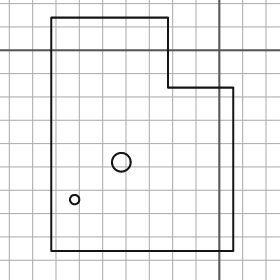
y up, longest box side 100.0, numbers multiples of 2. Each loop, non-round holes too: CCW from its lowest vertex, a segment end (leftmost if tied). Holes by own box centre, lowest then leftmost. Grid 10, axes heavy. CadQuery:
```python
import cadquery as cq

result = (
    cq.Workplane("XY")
    .moveTo(-72.0, -86.0)
    .lineTo(6.0, -86.0)
    .lineTo(6.0, -16.0)
    .lineTo(-22.0, -16.0)
    .lineTo(-22.0, 14.0)
    .lineTo(-72.0, 14.0)
    .close()
    .moveTo(-62.0, -64.0)
    .circle(2.0)
    .moveTo(-42.0, -48.0)
    .circle(4.0)
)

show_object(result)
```